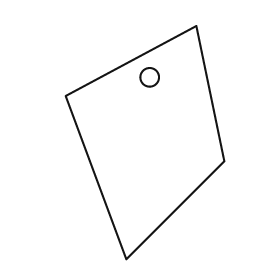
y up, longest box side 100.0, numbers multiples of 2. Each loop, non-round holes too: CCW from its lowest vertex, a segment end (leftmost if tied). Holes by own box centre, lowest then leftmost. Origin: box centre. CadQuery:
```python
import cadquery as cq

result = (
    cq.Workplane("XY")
    .moveTo(-8.0, -50.0)
    .lineTo(34.0, -8.0)
    .lineTo(22.0, 50.0)
    .lineTo(-34.0, 20.0)
    .close()
    .moveTo(2.0, 28.0)
    .circle(4.0)
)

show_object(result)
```